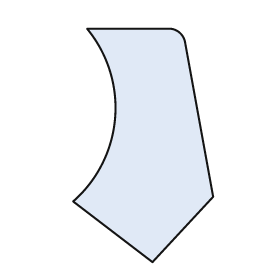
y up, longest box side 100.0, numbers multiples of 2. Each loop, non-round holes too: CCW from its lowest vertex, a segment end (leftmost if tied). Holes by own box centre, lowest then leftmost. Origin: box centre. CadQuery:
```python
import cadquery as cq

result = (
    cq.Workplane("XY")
    .moveTo(4.0, -50.0)
    .lineTo(30.0, -22.0)
    .lineTo(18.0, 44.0)
    .threePointArc((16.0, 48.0), (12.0, 50.0))
    .lineTo(-24.0, 50.0)
    .threePointArc((-12.0, 12.0), (-30.0, -24.0))
    .close()
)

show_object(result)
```